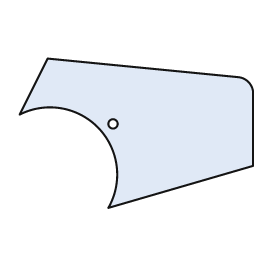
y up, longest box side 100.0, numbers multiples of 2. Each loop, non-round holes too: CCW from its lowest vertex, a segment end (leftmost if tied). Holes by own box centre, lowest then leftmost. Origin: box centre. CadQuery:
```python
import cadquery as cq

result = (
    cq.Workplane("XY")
    .moveTo(-12.0, -32.0)
    .lineTo(50.0, -14.0)
    .lineTo(50.0, 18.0)
    .threePointArc((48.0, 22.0), (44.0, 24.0))
    .lineTo(-38.0, 32.0)
    .lineTo(-50.0, 8.0)
    .threePointArc((-16.0, 2.0), (-12.0, -32.0))
    .close()
    .moveTo(-10.0, 4.0)
    .circle(2.0)
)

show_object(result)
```